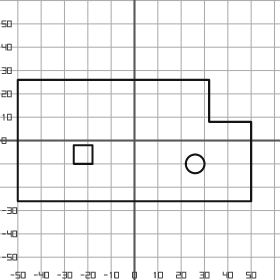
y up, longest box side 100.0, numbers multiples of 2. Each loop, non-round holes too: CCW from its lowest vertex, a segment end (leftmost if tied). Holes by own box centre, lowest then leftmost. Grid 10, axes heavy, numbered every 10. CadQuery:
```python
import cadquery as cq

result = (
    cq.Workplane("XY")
    .moveTo(-50.0, -26.0)
    .lineTo(50.0, -26.0)
    .lineTo(50.0, 8.0)
    .lineTo(32.0, 8.0)
    .lineTo(32.0, 26.0)
    .lineTo(-50.0, 26.0)
    .close()
    .moveTo(26.0, -10.0)
    .circle(4.0)
    .moveTo(-26.0, -10.0)
    .lineTo(-18.0, -10.0)
    .lineTo(-18.0, -2.0)
    .lineTo(-26.0, -2.0)
    .close()
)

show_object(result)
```